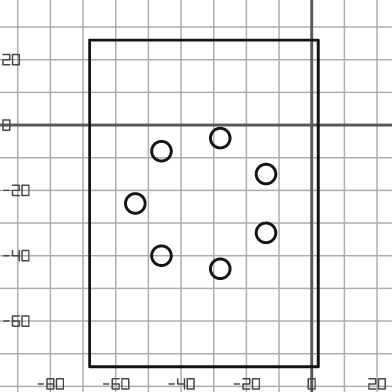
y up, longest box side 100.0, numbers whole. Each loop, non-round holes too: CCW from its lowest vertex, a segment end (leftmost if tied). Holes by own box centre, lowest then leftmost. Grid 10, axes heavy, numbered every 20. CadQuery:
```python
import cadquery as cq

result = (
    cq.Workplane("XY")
    .moveTo(-68.0, -74.0)
    .lineTo(2.0, -74.0)
    .lineTo(2.0, 26.0)
    .lineTo(-68.0, 26.0)
    .close()
    .moveTo(-28.0, -44.0)
    .circle(3.0)
    .moveTo(-46.0, -40.0)
    .circle(3.0)
    .moveTo(-14.0, -33.0)
    .circle(3.0)
    .moveTo(-54.0, -24.0)
    .circle(3.0)
    .moveTo(-14.0, -15.0)
    .circle(3.0)
    .moveTo(-46.0, -8.0)
    .circle(3.0)
    .moveTo(-28.0, -4.0)
    .circle(3.0)
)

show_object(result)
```